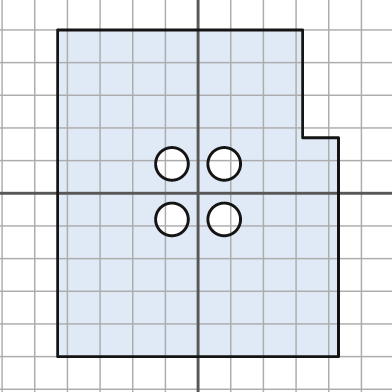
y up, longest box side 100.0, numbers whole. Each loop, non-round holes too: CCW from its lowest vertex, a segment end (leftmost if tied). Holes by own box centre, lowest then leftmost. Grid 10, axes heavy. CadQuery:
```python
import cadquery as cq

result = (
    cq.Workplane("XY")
    .moveTo(-43.0, -50.0)
    .lineTo(43.0, -50.0)
    .lineTo(43.0, 17.0)
    .lineTo(32.0, 17.0)
    .lineTo(32.0, 50.0)
    .lineTo(-43.0, 50.0)
    .close()
    .moveTo(-8.0, -8.0)
    .circle(5.0)
    .moveTo(8.0, -8.0)
    .circle(5.0)
    .moveTo(-8.0, 9.0)
    .circle(5.0)
    .moveTo(8.0, 9.0)
    .circle(5.0)
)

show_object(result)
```